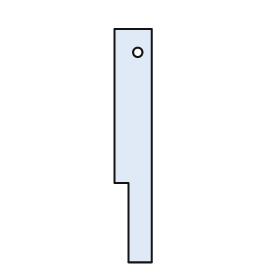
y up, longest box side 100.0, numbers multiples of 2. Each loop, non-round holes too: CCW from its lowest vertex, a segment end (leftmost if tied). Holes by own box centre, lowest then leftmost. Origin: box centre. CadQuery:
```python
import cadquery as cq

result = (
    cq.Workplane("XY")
    .moveTo(-2.0, -50.0)
    .lineTo(8.0, -50.0)
    .lineTo(8.0, 50.0)
    .lineTo(-8.0, 50.0)
    .lineTo(-8.0, -16.0)
    .lineTo(-2.0, -16.0)
    .close()
    .moveTo(2.0, 40.0)
    .circle(2.0)
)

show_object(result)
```